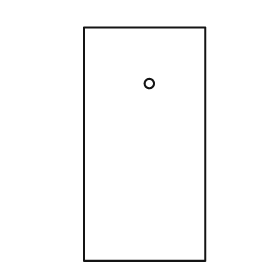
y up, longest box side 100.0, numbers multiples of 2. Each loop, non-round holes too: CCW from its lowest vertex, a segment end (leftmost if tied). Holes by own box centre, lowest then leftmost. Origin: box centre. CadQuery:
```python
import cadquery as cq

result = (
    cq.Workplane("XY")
    .moveTo(-26.0, -50.0)
    .lineTo(26.0, -50.0)
    .lineTo(26.0, 50.0)
    .lineTo(-26.0, 50.0)
    .close()
    .moveTo(2.0, 26.0)
    .circle(2.0)
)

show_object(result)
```